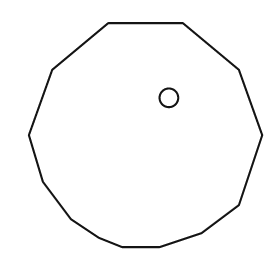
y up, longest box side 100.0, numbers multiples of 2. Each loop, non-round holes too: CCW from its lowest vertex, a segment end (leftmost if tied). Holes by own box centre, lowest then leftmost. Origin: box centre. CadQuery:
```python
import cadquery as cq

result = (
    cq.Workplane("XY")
    .moveTo(-10.0, -48.0)
    .lineTo(6.0, -48.0)
    .lineTo(24.0, -42.0)
    .lineTo(40.0, -30.0)
    .lineTo(50.0, 0.0)
    .lineTo(40.0, 28.0)
    .lineTo(16.0, 48.0)
    .lineTo(-16.0, 48.0)
    .lineTo(-40.0, 28.0)
    .lineTo(-50.0, 0.0)
    .lineTo(-44.0, -20.0)
    .lineTo(-32.0, -36.0)
    .lineTo(-20.0, -44.0)
    .close()
    .moveTo(10.0, 16.0)
    .circle(4.0)
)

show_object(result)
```